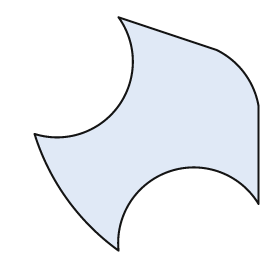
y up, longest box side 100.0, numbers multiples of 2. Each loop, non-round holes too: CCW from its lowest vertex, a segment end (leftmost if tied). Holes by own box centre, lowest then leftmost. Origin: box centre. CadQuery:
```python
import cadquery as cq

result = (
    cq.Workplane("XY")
    .moveTo(-12.0, -50.0)
    .threePointArc((10.0, -16.0), (48.0, -30.0))
    .lineTo(48.0, 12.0)
    .threePointArc((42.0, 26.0), (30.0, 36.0))
    .lineTo(-12.0, 50.0)
    .threePointArc((-12.0, 12.0), (-48.0, 0.0))
    .threePointArc((-34.0, -28.0), (-12.0, -50.0))
    .close()
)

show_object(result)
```